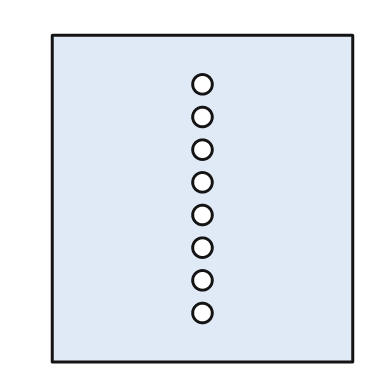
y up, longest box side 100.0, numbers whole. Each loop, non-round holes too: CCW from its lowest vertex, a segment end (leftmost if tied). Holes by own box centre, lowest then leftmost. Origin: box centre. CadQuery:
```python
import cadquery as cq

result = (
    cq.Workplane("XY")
    .moveTo(-46.0, -50.0)
    .lineTo(46.0, -50.0)
    .lineTo(46.0, 50.0)
    .lineTo(-46.0, 50.0)
    .close()
    .moveTo(0.0, -35.0)
    .circle(3.0)
    .moveTo(0.0, -25.0)
    .circle(3.0)
    .moveTo(0.0, -15.0)
    .circle(3.0)
    .moveTo(0.0, -5.0)
    .circle(3.0)
    .moveTo(0.0, 5.0)
    .circle(3.0)
    .moveTo(0.0, 15.0)
    .circle(3.0)
    .moveTo(0.0, 25.0)
    .circle(3.0)
    .moveTo(0.0, 35.0)
    .circle(3.0)
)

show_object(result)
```